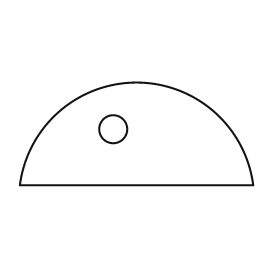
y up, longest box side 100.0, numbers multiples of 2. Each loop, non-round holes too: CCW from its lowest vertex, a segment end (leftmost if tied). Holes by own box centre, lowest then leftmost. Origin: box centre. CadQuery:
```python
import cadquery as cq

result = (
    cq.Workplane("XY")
    .moveTo(-50.0, -22.0)
    .lineTo(50.0, -22.0)
    .threePointArc((0.0, 22.0), (-50.0, -22.0))
    .close()
    .moveTo(-10.0, 2.0)
    .circle(6.0)
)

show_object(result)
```